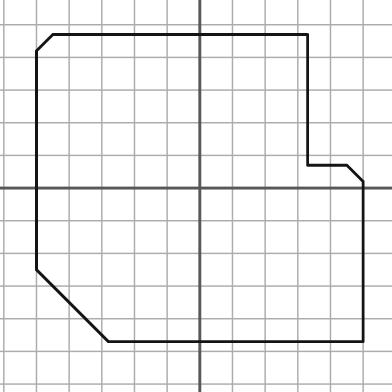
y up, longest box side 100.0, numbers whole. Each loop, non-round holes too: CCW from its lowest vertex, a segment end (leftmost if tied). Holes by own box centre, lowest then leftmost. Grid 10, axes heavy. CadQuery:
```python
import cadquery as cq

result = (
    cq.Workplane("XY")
    .moveTo(-28.0, -47.0)
    .lineTo(50.0, -47.0)
    .lineTo(50.0, 2.0)
    .lineTo(45.0, 7.0)
    .lineTo(33.0, 7.0)
    .lineTo(33.0, 47.0)
    .lineTo(-45.0, 47.0)
    .lineTo(-50.0, 42.0)
    .lineTo(-50.0, -25.0)
    .close()
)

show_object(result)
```